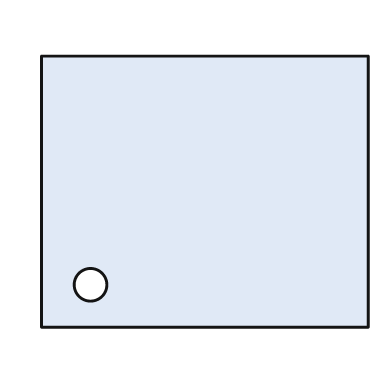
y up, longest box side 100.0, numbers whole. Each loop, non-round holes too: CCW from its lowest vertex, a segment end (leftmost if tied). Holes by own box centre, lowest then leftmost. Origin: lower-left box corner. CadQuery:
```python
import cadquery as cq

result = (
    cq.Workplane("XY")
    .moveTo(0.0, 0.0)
    .lineTo(100.0, 0.0)
    .lineTo(100.0, 83.0)
    .lineTo(0.0, 83.0)
    .close()
    .moveTo(15.0, 13.0)
    .circle(5.0)
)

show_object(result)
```